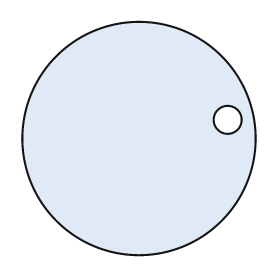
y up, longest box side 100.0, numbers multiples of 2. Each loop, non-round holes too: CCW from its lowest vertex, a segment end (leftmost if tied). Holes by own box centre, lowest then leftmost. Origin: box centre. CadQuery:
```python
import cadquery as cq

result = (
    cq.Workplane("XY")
    .moveTo(0.0, 0.0)
    .circle(50.0)
    .moveTo(38.0, 8.0)
    .circle(6.0)
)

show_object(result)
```